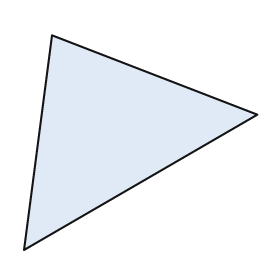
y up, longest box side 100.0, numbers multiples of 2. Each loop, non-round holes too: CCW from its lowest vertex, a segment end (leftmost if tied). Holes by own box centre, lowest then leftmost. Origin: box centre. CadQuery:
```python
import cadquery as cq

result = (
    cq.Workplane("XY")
    .moveTo(-50.0, -46.0)
    .lineTo(50.0, 12.0)
    .lineTo(-38.0, 46.0)
    .close()
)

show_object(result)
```